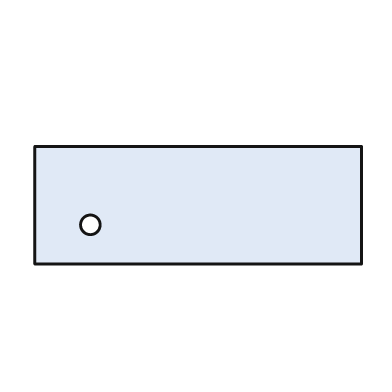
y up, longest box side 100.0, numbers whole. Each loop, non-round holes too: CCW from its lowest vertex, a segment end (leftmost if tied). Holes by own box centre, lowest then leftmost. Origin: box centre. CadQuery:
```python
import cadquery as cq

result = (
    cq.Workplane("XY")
    .moveTo(-50.0, -18.0)
    .lineTo(50.0, -18.0)
    .lineTo(50.0, 18.0)
    .lineTo(-50.0, 18.0)
    .close()
    .moveTo(-33.0, -6.0)
    .circle(3.0)
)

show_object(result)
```